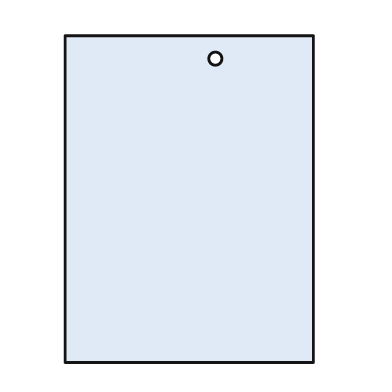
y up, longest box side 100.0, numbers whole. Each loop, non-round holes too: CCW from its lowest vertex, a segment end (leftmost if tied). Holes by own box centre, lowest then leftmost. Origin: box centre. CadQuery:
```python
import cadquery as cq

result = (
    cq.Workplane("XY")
    .moveTo(-38.0, -50.0)
    .lineTo(38.0, -50.0)
    .lineTo(38.0, 50.0)
    .lineTo(-38.0, 50.0)
    .close()
    .moveTo(8.0, 43.0)
    .circle(2.0)
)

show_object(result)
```